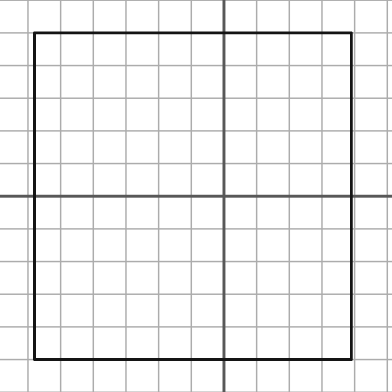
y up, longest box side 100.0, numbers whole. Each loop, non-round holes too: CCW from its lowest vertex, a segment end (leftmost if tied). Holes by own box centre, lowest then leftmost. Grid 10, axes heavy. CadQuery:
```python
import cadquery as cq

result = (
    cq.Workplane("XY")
    .moveTo(-58.0, -50.0)
    .lineTo(39.0, -50.0)
    .lineTo(39.0, 50.0)
    .lineTo(-58.0, 50.0)
    .close()
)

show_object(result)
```